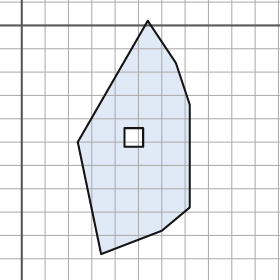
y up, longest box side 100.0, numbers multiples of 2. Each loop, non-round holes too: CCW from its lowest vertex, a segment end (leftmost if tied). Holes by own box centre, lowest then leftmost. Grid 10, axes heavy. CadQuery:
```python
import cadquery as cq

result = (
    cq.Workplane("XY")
    .moveTo(34.0, -98.0)
    .lineTo(60.0, -88.0)
    .lineTo(72.0, -78.0)
    .lineTo(72.0, -34.0)
    .lineTo(66.0, -16.0)
    .lineTo(54.0, 2.0)
    .lineTo(24.0, -50.0)
    .close()
    .moveTo(44.0, -52.0)
    .lineTo(52.0, -52.0)
    .lineTo(52.0, -44.0)
    .lineTo(44.0, -44.0)
    .close()
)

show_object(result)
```